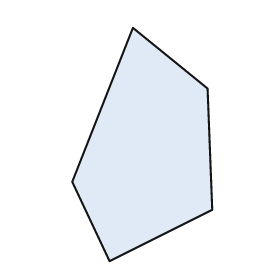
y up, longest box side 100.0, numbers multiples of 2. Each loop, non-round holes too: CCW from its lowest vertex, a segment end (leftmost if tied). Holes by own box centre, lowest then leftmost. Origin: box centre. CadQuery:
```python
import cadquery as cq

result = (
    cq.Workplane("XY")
    .moveTo(-14.0, -50.0)
    .lineTo(30.0, -28.0)
    .lineTo(28.0, 24.0)
    .lineTo(-4.0, 50.0)
    .lineTo(-30.0, -16.0)
    .close()
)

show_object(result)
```